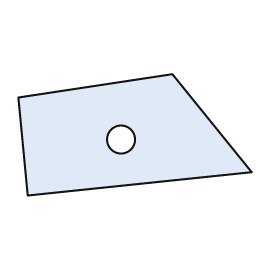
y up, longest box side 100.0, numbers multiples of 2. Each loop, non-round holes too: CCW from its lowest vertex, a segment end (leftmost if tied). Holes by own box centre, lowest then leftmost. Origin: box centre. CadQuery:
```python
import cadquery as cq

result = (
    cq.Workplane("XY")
    .moveTo(-46.0, -26.0)
    .lineTo(50.0, -16.0)
    .lineTo(16.0, 26.0)
    .lineTo(-50.0, 16.0)
    .close()
    .moveTo(-6.0, -2.0)
    .circle(6.0)
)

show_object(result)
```